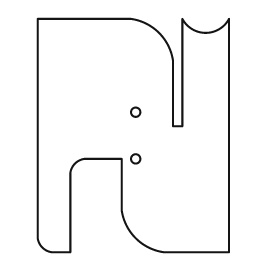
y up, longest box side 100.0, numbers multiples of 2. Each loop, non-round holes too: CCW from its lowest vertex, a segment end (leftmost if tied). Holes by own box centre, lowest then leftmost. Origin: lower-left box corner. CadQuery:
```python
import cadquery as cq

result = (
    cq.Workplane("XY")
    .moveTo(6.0, 0.0)
    .lineTo(14.0, 0.0)
    .lineTo(14.0, 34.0)
    .threePointArc((16.0, 38.0), (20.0, 40.0))
    .lineTo(36.0, 40.0)
    .lineTo(36.0, 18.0)
    .threePointArc((42.0, 6.0), (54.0, 0.0))
    .lineTo(82.0, 0.0)
    .lineTo(82.0, 100.0)
    .threePointArc((72.0, 94.0), (62.0, 100.0))
    .lineTo(62.0, 54.0)
    .lineTo(58.0, 54.0)
    .lineTo(58.0, 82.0)
    .threePointArc((52.0, 94.0), (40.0, 100.0))
    .lineTo(0.0, 100.0)
    .lineTo(0.0, 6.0)
    .threePointArc((2.0, 2.0), (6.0, 0.0))
    .close()
    .moveTo(42.0, 40.0)
    .circle(2.0)
    .moveTo(42.0, 60.0)
    .circle(2.0)
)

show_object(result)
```